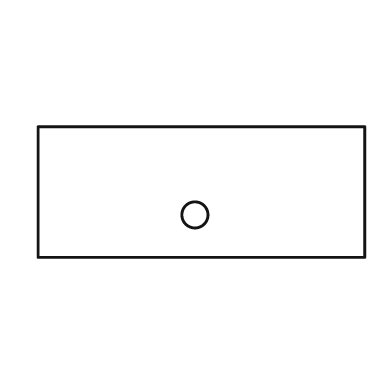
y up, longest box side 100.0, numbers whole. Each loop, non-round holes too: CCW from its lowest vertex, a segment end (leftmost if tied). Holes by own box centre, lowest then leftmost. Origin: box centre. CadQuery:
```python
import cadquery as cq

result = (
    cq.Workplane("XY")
    .moveTo(-50.0, -20.0)
    .lineTo(50.0, -20.0)
    .lineTo(50.0, 20.0)
    .lineTo(-50.0, 20.0)
    .close()
    .moveTo(-2.0, -7.0)
    .circle(4.0)
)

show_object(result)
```